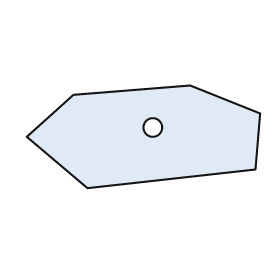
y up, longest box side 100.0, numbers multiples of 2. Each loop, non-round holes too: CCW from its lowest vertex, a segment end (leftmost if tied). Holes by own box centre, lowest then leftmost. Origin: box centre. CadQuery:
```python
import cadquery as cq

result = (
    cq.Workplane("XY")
    .moveTo(-24.0, -22.0)
    .lineTo(48.0, -14.0)
    .lineTo(50.0, 10.0)
    .lineTo(20.0, 22.0)
    .lineTo(-30.0, 18.0)
    .lineTo(-50.0, 0.0)
    .close()
    .moveTo(4.0, 4.0)
    .circle(4.0)
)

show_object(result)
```